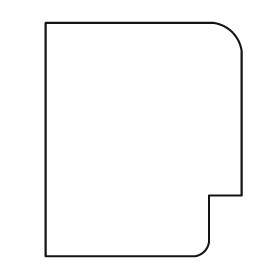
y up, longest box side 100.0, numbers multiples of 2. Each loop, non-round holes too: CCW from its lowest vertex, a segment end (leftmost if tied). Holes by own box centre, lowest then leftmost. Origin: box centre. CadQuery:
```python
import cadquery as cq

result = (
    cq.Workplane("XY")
    .moveTo(-42.0, -50.0)
    .lineTo(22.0, -50.0)
    .threePointArc((26.0, -48.0), (28.0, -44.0))
    .lineTo(28.0, -24.0)
    .lineTo(42.0, -24.0)
    .lineTo(42.0, 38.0)
    .threePointArc((38.0, 46.0), (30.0, 50.0))
    .lineTo(-42.0, 50.0)
    .close()
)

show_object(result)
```